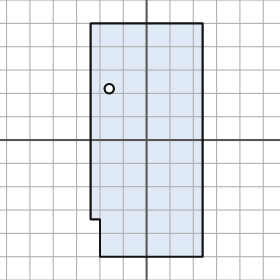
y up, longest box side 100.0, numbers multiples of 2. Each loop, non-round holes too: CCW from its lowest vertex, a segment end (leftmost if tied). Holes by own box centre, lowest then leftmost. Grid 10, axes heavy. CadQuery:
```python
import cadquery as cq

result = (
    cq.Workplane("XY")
    .moveTo(-20.0, -50.0)
    .lineTo(24.0, -50.0)
    .lineTo(24.0, 50.0)
    .lineTo(-24.0, 50.0)
    .lineTo(-24.0, -34.0)
    .lineTo(-20.0, -34.0)
    .close()
    .moveTo(-16.0, 22.0)
    .circle(2.0)
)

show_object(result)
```